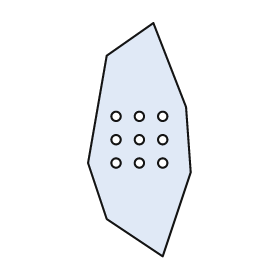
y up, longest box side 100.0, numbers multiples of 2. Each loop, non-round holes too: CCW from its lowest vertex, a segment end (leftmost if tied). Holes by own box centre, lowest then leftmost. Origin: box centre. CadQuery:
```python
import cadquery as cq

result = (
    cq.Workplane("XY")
    .moveTo(10.0, -50.0)
    .lineTo(22.0, -14.0)
    .lineTo(20.0, 14.0)
    .lineTo(6.0, 50.0)
    .lineTo(-14.0, 36.0)
    .lineTo(-22.0, -10.0)
    .lineTo(-14.0, -34.0)
    .close()
    .moveTo(-10.0, -10.0)
    .circle(2.0)
    .moveTo(0.0, -10.0)
    .circle(2.0)
    .moveTo(10.0, -10.0)
    .circle(2.0)
    .moveTo(-10.0, 0.0)
    .circle(2.0)
    .moveTo(0.0, 0.0)
    .circle(2.0)
    .moveTo(10.0, 0.0)
    .circle(2.0)
    .moveTo(-10.0, 10.0)
    .circle(2.0)
    .moveTo(0.0, 10.0)
    .circle(2.0)
    .moveTo(10.0, 10.0)
    .circle(2.0)
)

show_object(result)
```